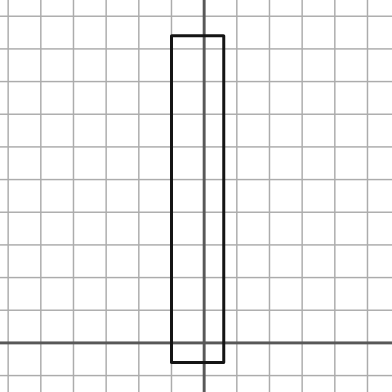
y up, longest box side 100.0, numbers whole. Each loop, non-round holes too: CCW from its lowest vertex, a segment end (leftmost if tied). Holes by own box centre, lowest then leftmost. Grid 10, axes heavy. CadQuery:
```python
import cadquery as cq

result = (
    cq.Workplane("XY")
    .moveTo(-10.0, -6.0)
    .lineTo(6.0, -6.0)
    .lineTo(6.0, 94.0)
    .lineTo(-10.0, 94.0)
    .close()
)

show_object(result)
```